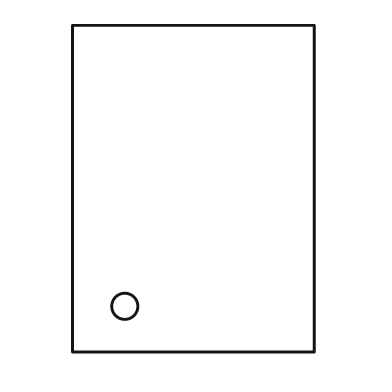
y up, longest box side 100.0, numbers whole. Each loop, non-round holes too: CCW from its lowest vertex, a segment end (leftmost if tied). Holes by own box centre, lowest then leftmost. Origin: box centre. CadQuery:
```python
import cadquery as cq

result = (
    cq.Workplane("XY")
    .moveTo(-37.0, -50.0)
    .lineTo(37.0, -50.0)
    .lineTo(37.0, 50.0)
    .lineTo(-37.0, 50.0)
    .close()
    .moveTo(-21.0, -36.0)
    .circle(4.0)
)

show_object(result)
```